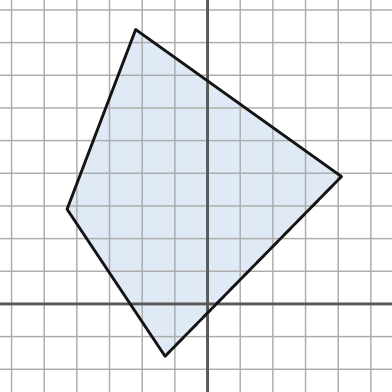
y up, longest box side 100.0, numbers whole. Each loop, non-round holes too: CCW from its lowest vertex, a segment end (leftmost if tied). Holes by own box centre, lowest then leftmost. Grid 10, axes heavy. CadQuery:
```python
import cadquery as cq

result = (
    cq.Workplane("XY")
    .moveTo(-13.0, -16.0)
    .lineTo(41.0, 39.0)
    .lineTo(-22.0, 84.0)
    .lineTo(-43.0, 29.0)
    .close()
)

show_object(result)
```